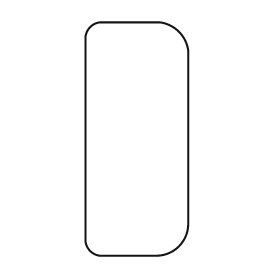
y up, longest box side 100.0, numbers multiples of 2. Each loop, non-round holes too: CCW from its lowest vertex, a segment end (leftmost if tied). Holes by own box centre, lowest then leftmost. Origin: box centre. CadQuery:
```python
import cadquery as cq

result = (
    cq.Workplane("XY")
    .moveTo(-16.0, -50.0)
    .lineTo(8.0, -50.0)
    .threePointArc((18.0, -46.0), (22.0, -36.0))
    .lineTo(22.0, 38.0)
    .threePointArc((18.0, 46.0), (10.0, 50.0))
    .lineTo(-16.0, 50.0)
    .threePointArc((-20.0, 48.0), (-22.0, 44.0))
    .lineTo(-22.0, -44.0)
    .threePointArc((-20.0, -48.0), (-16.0, -50.0))
    .close()
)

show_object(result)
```